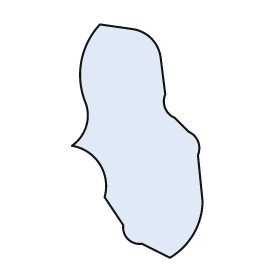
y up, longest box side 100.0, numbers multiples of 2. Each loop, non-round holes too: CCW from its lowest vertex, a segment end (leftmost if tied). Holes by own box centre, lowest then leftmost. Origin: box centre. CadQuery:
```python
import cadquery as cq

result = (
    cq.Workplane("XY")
    .moveTo(14.0, -50.0)
    .threePointArc((24.0, -40.0), (28.0, -26.0))
    .lineTo(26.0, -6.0)
    .threePointArc((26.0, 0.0), (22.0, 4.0))
    .lineTo(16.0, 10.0)
    .threePointArc((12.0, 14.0), (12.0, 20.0))
    .lineTo(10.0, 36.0)
    .threePointArc((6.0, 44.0), (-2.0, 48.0))
    .lineTo(-16.0, 50.0)
    .threePointArc((-24.0, 34.0), (-22.0, 16.0))
    .threePointArc((-22.0, 6.0), (-28.0, -2.0))
    .threePointArc((-16.0, -10.0), (-14.0, -24.0))
    .lineTo(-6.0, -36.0)
    .threePointArc((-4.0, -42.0), (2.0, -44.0))
    .close()
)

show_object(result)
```